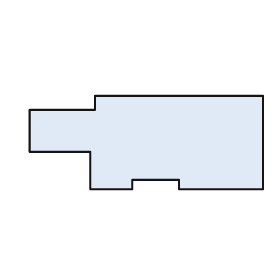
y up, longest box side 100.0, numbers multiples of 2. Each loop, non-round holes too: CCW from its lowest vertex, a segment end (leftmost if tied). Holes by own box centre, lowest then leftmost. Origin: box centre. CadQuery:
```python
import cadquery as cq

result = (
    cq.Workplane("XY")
    .moveTo(-24.0, -20.0)
    .lineTo(-6.0, -20.0)
    .lineTo(-6.0, -16.0)
    .lineTo(14.0, -16.0)
    .lineTo(14.0, -20.0)
    .lineTo(50.0, -20.0)
    .lineTo(50.0, 20.0)
    .lineTo(-22.0, 20.0)
    .lineTo(-22.0, 14.0)
    .lineTo(-50.0, 14.0)
    .lineTo(-50.0, -4.0)
    .lineTo(-24.0, -4.0)
    .close()
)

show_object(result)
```